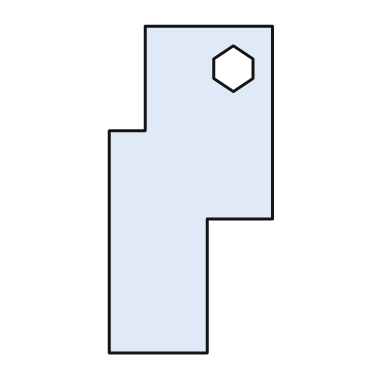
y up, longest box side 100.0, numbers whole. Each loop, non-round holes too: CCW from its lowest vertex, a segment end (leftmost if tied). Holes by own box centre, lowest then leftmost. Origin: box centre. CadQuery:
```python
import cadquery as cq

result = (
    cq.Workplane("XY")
    .moveTo(-25.0, -50.0)
    .lineTo(5.0, -50.0)
    .lineTo(5.0, -9.0)
    .lineTo(25.0, -9.0)
    .lineTo(25.0, 50.0)
    .lineTo(-14.0, 50.0)
    .lineTo(-14.0, 18.0)
    .lineTo(-25.0, 18.0)
    .close()
    .moveTo(13.0, 30.0)
    .lineTo(19.0, 34.0)
    .lineTo(19.0, 40.0)
    .lineTo(13.0, 44.0)
    .lineTo(7.0, 40.0)
    .lineTo(7.0, 34.0)
    .close()
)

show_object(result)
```